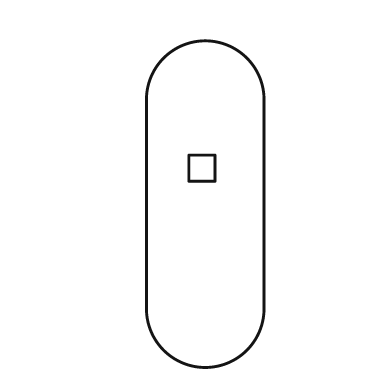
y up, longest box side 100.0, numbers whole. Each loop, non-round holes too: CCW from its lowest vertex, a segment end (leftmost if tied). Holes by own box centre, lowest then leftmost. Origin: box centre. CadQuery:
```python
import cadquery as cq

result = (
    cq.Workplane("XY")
    .moveTo(-18.0, -32.0)
    .threePointArc((0.0, -50.0), (18.0, -32.0))
    .lineTo(18.0, 32.0)
    .threePointArc((0.0, 50.0), (-18.0, 32.0))
    .close()
    .moveTo(-5.0, 7.0)
    .lineTo(3.0, 7.0)
    .lineTo(3.0, 15.0)
    .lineTo(-5.0, 15.0)
    .close()
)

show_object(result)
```